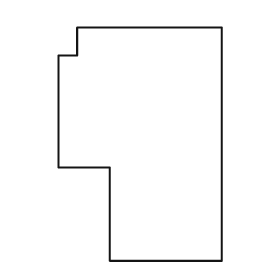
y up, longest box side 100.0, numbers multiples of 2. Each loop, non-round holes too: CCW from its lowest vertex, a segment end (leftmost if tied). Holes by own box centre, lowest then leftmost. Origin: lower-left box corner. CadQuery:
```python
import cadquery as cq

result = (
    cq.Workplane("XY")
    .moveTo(22.0, 0.0)
    .lineTo(70.0, 0.0)
    .lineTo(70.0, 100.0)
    .lineTo(8.0, 100.0)
    .lineTo(8.0, 88.0)
    .lineTo(0.0, 88.0)
    .lineTo(0.0, 40.0)
    .lineTo(22.0, 40.0)
    .close()
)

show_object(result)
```